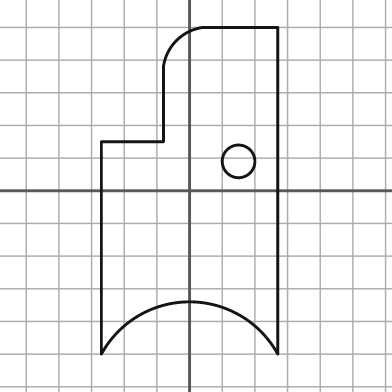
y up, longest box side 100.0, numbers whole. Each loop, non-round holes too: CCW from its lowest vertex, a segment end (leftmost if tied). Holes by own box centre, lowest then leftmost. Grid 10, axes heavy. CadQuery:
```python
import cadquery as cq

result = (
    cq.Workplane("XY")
    .moveTo(-27.0, -50.0)
    .threePointArc((0.0, -34.0), (27.0, -50.0))
    .lineTo(27.0, 50.0)
    .lineTo(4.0, 50.0)
    .threePointArc((-4.0, 46.0), (-8.0, 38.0))
    .lineTo(-8.0, 15.0)
    .lineTo(-27.0, 15.0)
    .close()
    .moveTo(15.0, 9.0)
    .circle(5.0)
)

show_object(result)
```